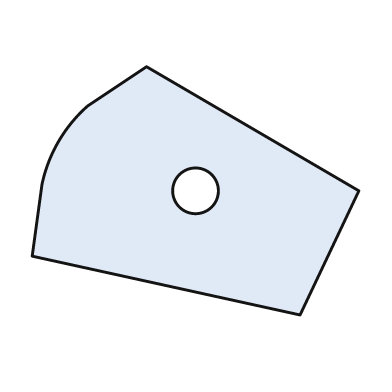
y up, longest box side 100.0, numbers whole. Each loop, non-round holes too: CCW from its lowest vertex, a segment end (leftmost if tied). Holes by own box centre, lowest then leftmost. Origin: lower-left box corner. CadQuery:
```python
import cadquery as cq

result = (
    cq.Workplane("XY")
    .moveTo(82.0, 0.0)
    .lineTo(100.0, 38.0)
    .lineTo(35.0, 76.0)
    .lineTo(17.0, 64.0)
    .threePointArc((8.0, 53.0), (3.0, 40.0))
    .lineTo(0.0, 18.0)
    .close()
    .moveTo(50.0, 38.0)
    .circle(7.0)
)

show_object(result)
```